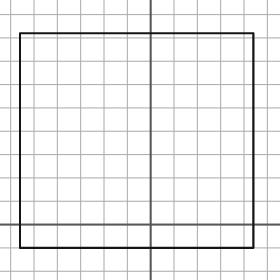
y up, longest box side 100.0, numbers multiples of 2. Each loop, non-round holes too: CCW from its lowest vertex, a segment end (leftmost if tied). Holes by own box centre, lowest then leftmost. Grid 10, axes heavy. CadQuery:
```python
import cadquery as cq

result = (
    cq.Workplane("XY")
    .moveTo(-56.0, -10.0)
    .lineTo(44.0, -10.0)
    .lineTo(44.0, 82.0)
    .lineTo(-56.0, 82.0)
    .close()
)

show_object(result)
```